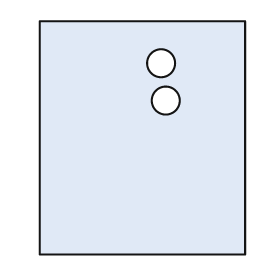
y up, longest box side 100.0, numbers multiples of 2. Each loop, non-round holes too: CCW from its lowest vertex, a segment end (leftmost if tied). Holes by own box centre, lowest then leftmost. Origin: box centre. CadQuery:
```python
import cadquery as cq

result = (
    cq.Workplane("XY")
    .moveTo(-44.0, -50.0)
    .lineTo(44.0, -50.0)
    .lineTo(44.0, 50.0)
    .lineTo(-44.0, 50.0)
    .close()
    .moveTo(10.0, 16.0)
    .circle(6.0)
    .moveTo(8.0, 32.0)
    .circle(6.0)
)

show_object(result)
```